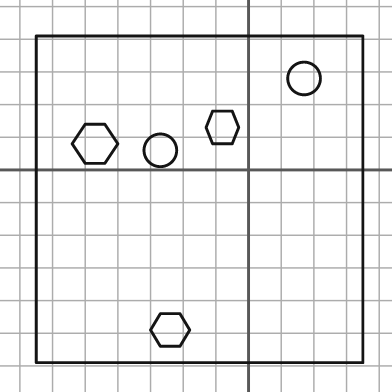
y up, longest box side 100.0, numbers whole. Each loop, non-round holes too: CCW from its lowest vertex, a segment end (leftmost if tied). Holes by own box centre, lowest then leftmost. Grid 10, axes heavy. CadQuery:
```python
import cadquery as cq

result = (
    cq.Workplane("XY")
    .moveTo(-65.0, -59.0)
    .lineTo(35.0, -59.0)
    .lineTo(35.0, 41.0)
    .lineTo(-65.0, 41.0)
    .close()
    .moveTo(-27.0, -54.0)
    .lineTo(-21.0, -54.0)
    .lineTo(-18.0, -49.0)
    .lineTo(-21.0, -44.0)
    .lineTo(-27.0, -44.0)
    .lineTo(-30.0, -49.0)
    .close()
    .moveTo(-27.0, 6.0)
    .circle(5.0)
    .moveTo(-50.0, 2.0)
    .lineTo(-44.0, 2.0)
    .lineTo(-40.0, 8.0)
    .lineTo(-44.0, 14.0)
    .lineTo(-50.0, 14.0)
    .lineTo(-54.0, 8.0)
    .close()
    .moveTo(-11.0, 8.0)
    .lineTo(-5.0, 8.0)
    .lineTo(-3.0, 13.0)
    .lineTo(-5.0, 18.0)
    .lineTo(-11.0, 18.0)
    .lineTo(-13.0, 13.0)
    .close()
    .moveTo(17.0, 28.0)
    .circle(5.0)
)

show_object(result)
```